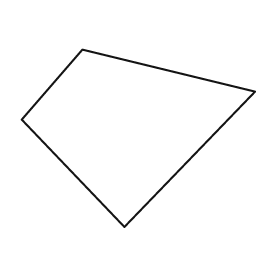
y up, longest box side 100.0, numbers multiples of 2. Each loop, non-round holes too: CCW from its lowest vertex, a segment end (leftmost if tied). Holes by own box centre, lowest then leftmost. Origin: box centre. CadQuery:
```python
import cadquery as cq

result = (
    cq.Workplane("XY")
    .moveTo(-6.0, -38.0)
    .lineTo(50.0, 20.0)
    .lineTo(-24.0, 38.0)
    .lineTo(-50.0, 8.0)
    .close()
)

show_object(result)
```